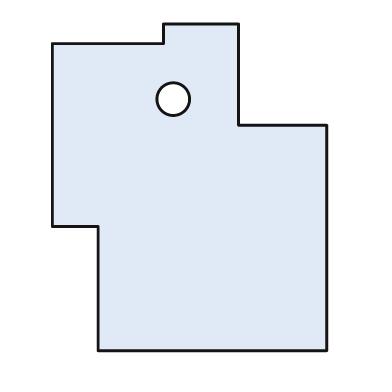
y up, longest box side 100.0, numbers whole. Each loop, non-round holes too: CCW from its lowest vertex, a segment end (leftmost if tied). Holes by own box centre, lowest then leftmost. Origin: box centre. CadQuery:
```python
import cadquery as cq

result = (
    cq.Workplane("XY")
    .moveTo(-28.0, -50.0)
    .lineTo(42.0, -50.0)
    .lineTo(42.0, 19.0)
    .lineTo(15.0, 19.0)
    .lineTo(15.0, 50.0)
    .lineTo(-8.0, 50.0)
    .lineTo(-8.0, 44.0)
    .lineTo(-42.0, 44.0)
    .lineTo(-42.0, -12.0)
    .lineTo(-28.0, -12.0)
    .close()
    .moveTo(-5.0, 27.0)
    .circle(5.0)
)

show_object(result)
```